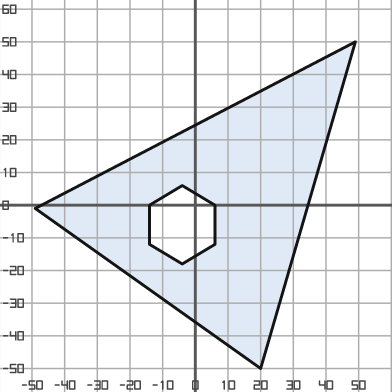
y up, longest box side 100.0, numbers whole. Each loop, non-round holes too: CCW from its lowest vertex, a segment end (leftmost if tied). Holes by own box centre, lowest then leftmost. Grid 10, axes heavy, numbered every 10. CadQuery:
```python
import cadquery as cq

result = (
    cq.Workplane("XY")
    .moveTo(20.0, -50.0)
    .lineTo(49.0, 50.0)
    .lineTo(-49.0, -1.0)
    .close()
    .moveTo(-4.0, -18.0)
    .lineTo(6.0, -12.0)
    .lineTo(6.0, 0.0)
    .lineTo(-4.0, 6.0)
    .lineTo(-14.0, 0.0)
    .lineTo(-14.0, -12.0)
    .close()
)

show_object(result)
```